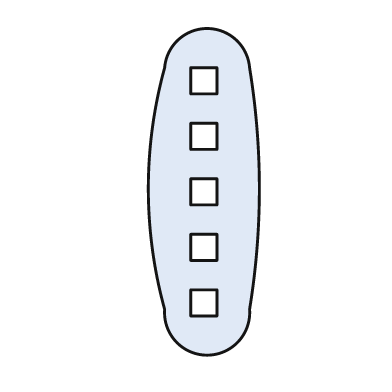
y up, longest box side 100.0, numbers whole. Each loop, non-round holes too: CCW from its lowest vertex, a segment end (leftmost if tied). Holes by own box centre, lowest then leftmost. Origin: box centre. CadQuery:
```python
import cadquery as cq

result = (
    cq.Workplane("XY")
    .moveTo(-12.0, -36.0)
    .threePointArc((1.0, -50.0), (14.0, -36.0))
    .threePointArc((17.0, 1.0), (14.0, 38.0))
    .threePointArc((1.0, 50.0), (-12.0, 38.0))
    .threePointArc((-17.0, 1.0), (-12.0, -36.0))
    .close()
    .moveTo(-4.0, -38.0)
    .lineTo(4.0, -38.0)
    .lineTo(4.0, -30.0)
    .lineTo(-4.0, -30.0)
    .close()
    .moveTo(-4.0, -21.0)
    .lineTo(4.0, -21.0)
    .lineTo(4.0, -13.0)
    .lineTo(-4.0, -13.0)
    .close()
    .moveTo(-4.0, -4.0)
    .lineTo(4.0, -4.0)
    .lineTo(4.0, 4.0)
    .lineTo(-4.0, 4.0)
    .close()
    .moveTo(-4.0, 13.0)
    .lineTo(4.0, 13.0)
    .lineTo(4.0, 21.0)
    .lineTo(-4.0, 21.0)
    .close()
    .moveTo(-4.0, 30.0)
    .lineTo(4.0, 30.0)
    .lineTo(4.0, 38.0)
    .lineTo(-4.0, 38.0)
    .close()
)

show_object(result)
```